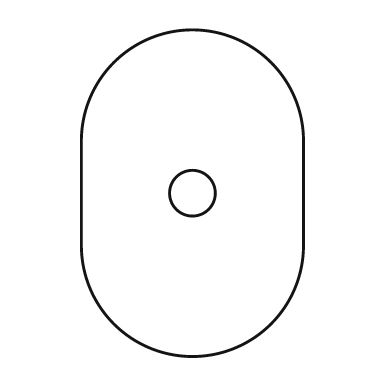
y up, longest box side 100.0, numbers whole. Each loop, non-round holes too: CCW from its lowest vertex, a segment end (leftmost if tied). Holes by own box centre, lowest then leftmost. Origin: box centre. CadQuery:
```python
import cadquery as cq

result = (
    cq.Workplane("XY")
    .moveTo(-34.0, -16.0)
    .threePointArc((0.0, -50.0), (34.0, -16.0))
    .lineTo(34.0, 16.0)
    .threePointArc((0.0, 50.0), (-34.0, 16.0))
    .close()
    .moveTo(0.0, 0.0)
    .circle(7.0)
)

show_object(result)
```